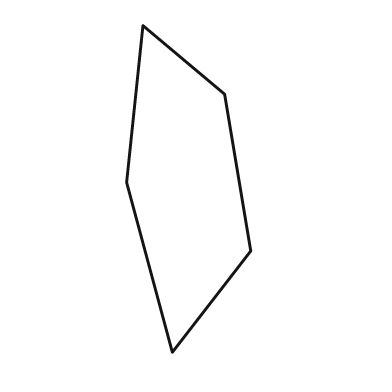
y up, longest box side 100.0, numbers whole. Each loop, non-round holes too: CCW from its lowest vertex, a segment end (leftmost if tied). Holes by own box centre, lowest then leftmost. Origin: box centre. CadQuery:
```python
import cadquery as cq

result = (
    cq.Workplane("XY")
    .moveTo(-5.0, -50.0)
    .lineTo(19.0, -19.0)
    .lineTo(11.0, 29.0)
    .lineTo(-14.0, 50.0)
    .lineTo(-19.0, 2.0)
    .close()
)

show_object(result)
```